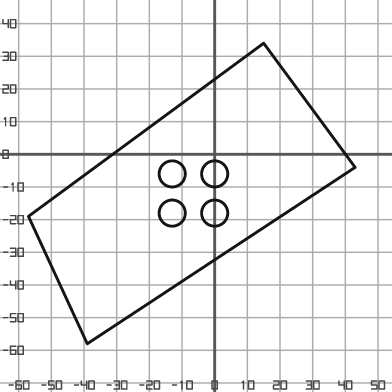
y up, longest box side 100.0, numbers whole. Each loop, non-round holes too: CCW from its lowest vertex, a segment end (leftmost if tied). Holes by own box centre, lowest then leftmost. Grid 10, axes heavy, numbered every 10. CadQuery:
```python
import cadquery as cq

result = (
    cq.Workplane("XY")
    .moveTo(-39.0, -58.0)
    .lineTo(43.0, -4.0)
    .lineTo(15.0, 34.0)
    .lineTo(-57.0, -19.0)
    .close()
    .moveTo(-13.0, -18.0)
    .circle(4.0)
    .moveTo(0.0, -18.0)
    .circle(4.0)
    .moveTo(-13.0, -6.0)
    .circle(4.0)
    .moveTo(0.0, -6.0)
    .circle(4.0)
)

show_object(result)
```